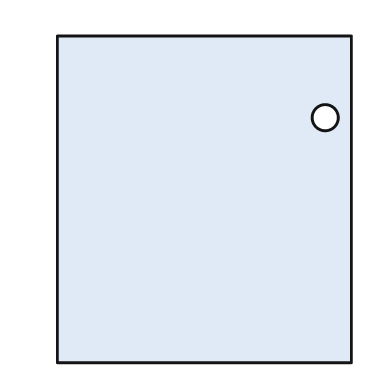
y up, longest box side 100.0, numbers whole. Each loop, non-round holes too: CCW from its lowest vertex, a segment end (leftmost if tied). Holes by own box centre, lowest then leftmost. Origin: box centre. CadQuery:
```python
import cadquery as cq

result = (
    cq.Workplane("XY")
    .moveTo(-45.0, -50.0)
    .lineTo(45.0, -50.0)
    .lineTo(45.0, 50.0)
    .lineTo(-45.0, 50.0)
    .close()
    .moveTo(37.0, 25.0)
    .circle(4.0)
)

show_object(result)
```